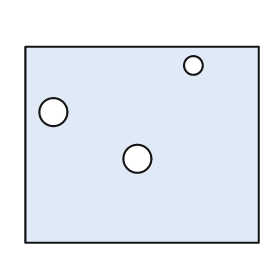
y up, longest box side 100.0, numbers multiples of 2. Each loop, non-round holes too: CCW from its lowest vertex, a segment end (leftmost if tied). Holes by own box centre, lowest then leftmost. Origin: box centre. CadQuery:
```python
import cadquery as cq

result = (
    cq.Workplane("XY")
    .moveTo(-50.0, -42.0)
    .lineTo(50.0, -42.0)
    .lineTo(50.0, 42.0)
    .lineTo(-50.0, 42.0)
    .close()
    .moveTo(-2.0, -6.0)
    .circle(6.0)
    .moveTo(-38.0, 14.0)
    .circle(6.0)
    .moveTo(22.0, 34.0)
    .circle(4.0)
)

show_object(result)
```